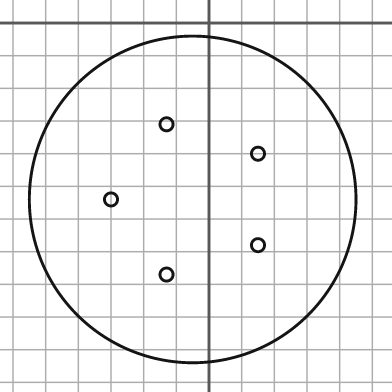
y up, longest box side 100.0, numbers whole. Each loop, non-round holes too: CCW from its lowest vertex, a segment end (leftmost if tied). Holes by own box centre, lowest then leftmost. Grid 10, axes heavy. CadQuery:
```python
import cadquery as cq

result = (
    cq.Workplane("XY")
    .moveTo(-5.0, -54.0)
    .circle(50.0)
    .moveTo(-13.0, -77.0)
    .circle(2.0)
    .moveTo(15.0, -68.0)
    .circle(2.0)
    .moveTo(-30.0, -54.0)
    .circle(2.0)
    .moveTo(15.0, -40.0)
    .circle(2.0)
    .moveTo(-13.0, -31.0)
    .circle(2.0)
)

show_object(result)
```